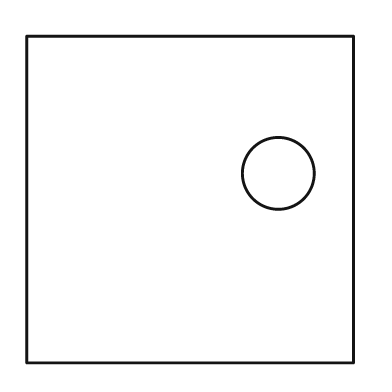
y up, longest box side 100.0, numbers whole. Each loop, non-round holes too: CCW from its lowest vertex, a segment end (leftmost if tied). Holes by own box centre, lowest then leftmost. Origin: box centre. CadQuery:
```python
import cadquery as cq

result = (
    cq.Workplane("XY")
    .moveTo(-50.0, -50.0)
    .lineTo(50.0, -50.0)
    .lineTo(50.0, 50.0)
    .lineTo(-50.0, 50.0)
    .close()
    .moveTo(27.0, 8.0)
    .circle(11.0)
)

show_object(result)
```